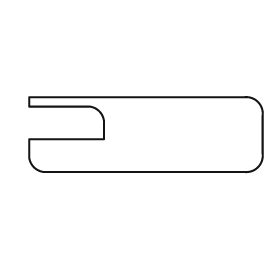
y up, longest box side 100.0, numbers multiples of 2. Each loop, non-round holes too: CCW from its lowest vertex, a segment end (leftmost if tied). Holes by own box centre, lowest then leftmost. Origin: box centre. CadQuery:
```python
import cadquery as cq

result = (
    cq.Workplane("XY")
    .moveTo(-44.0, -16.0)
    .lineTo(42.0, -16.0)
    .threePointArc((48.0, -14.0), (50.0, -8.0))
    .lineTo(50.0, 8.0)
    .threePointArc((48.0, 14.0), (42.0, 16.0))
    .lineTo(-50.0, 16.0)
    .lineTo(-50.0, 12.0)
    .lineTo(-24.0, 12.0)
    .threePointArc((-20.0, 10.0), (-18.0, 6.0))
    .lineTo(-18.0, -2.0)
    .lineTo(-50.0, -2.0)
    .lineTo(-50.0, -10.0)
    .threePointArc((-48.0, -14.0), (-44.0, -16.0))
    .close()
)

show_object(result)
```